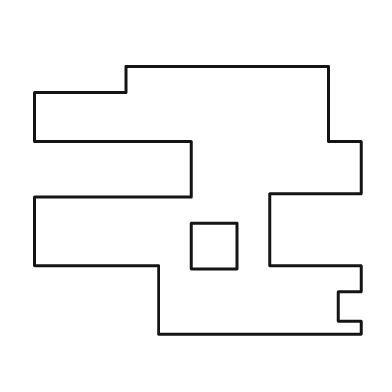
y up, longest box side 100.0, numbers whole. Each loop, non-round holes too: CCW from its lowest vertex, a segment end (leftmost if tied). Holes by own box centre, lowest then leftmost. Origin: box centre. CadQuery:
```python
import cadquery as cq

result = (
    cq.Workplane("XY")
    .moveTo(-12.0, -41.0)
    .lineTo(50.0, -41.0)
    .lineTo(50.0, -37.0)
    .lineTo(43.0, -37.0)
    .lineTo(43.0, -28.0)
    .lineTo(50.0, -28.0)
    .lineTo(50.0, -20.0)
    .lineTo(22.0, -20.0)
    .lineTo(22.0, 2.0)
    .lineTo(50.0, 2.0)
    .lineTo(50.0, 18.0)
    .lineTo(40.0, 18.0)
    .lineTo(40.0, 41.0)
    .lineTo(-22.0, 41.0)
    .lineTo(-22.0, 33.0)
    .lineTo(-50.0, 33.0)
    .lineTo(-50.0, 18.0)
    .lineTo(-2.0, 18.0)
    .lineTo(-2.0, 1.0)
    .lineTo(-50.0, 1.0)
    .lineTo(-50.0, -20.0)
    .lineTo(-12.0, -20.0)
    .close()
    .moveTo(-2.0, -21.0)
    .lineTo(12.0, -21.0)
    .lineTo(12.0, -7.0)
    .lineTo(-2.0, -7.0)
    .close()
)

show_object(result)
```